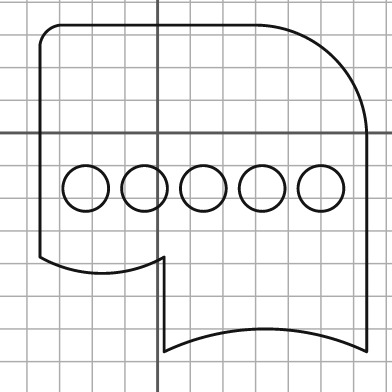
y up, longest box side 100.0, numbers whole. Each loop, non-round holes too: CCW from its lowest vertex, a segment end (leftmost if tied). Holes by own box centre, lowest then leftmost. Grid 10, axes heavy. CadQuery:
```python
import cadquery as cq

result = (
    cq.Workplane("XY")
    .moveTo(2.0, -67.0)
    .threePointArc((33.0, -60.0), (64.0, -67.0))
    .lineTo(64.0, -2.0)
    .threePointArc((54.0, 23.0), (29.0, 33.0))
    .lineTo(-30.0, 33.0)
    .threePointArc((-34.0, 31.0), (-36.0, 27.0))
    .lineTo(-36.0, -38.0)
    .threePointArc((-17.0, -43.0), (2.0, -38.0))
    .close()
    .moveTo(-22.0, -17.0)
    .circle(7.0)
    .moveTo(-4.0, -17.0)
    .circle(7.0)
    .moveTo(14.0, -17.0)
    .circle(7.0)
    .moveTo(32.0, -17.0)
    .circle(7.0)
    .moveTo(50.0, -17.0)
    .circle(7.0)
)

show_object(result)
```